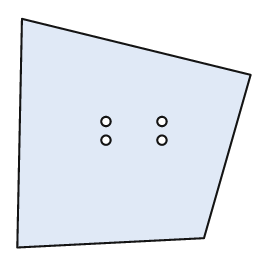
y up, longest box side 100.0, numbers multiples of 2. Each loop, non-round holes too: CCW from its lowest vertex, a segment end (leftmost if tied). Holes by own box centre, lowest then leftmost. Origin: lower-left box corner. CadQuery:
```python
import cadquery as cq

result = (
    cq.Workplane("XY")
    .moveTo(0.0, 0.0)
    .lineTo(80.0, 4.0)
    .lineTo(100.0, 74.0)
    .lineTo(2.0, 98.0)
    .close()
    .moveTo(38.0, 46.0)
    .circle(2.0)
    .moveTo(62.0, 46.0)
    .circle(2.0)
    .moveTo(38.0, 54.0)
    .circle(2.0)
    .moveTo(62.0, 54.0)
    .circle(2.0)
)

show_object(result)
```